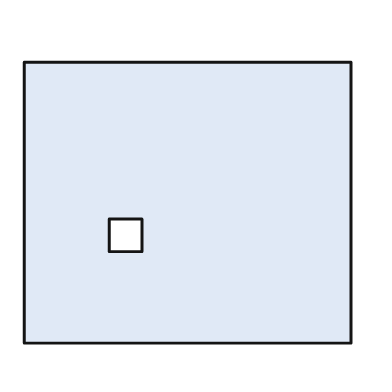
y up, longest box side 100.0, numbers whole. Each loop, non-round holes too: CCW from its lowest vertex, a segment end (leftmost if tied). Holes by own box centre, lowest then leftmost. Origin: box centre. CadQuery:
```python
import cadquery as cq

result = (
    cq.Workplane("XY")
    .moveTo(-50.0, -43.0)
    .lineTo(50.0, -43.0)
    .lineTo(50.0, 43.0)
    .lineTo(-50.0, 43.0)
    .close()
    .moveTo(-24.0, -15.0)
    .lineTo(-14.0, -15.0)
    .lineTo(-14.0, -5.0)
    .lineTo(-24.0, -5.0)
    .close()
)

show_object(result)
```